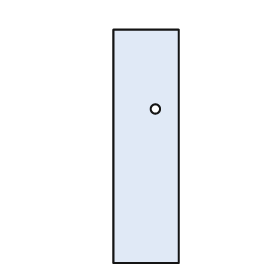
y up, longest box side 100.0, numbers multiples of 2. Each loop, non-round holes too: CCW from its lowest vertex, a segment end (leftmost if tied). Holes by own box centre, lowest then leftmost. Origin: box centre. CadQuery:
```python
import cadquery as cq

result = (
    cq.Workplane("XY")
    .moveTo(-14.0, -50.0)
    .lineTo(14.0, -50.0)
    .lineTo(14.0, 50.0)
    .lineTo(-14.0, 50.0)
    .close()
    .moveTo(4.0, 16.0)
    .circle(2.0)
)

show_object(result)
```